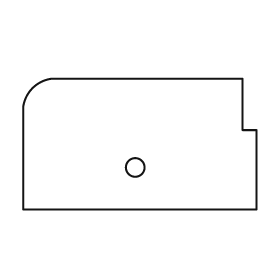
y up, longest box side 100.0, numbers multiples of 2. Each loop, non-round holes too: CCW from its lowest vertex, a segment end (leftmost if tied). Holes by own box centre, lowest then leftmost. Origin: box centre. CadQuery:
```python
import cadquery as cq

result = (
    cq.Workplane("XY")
    .moveTo(-50.0, -28.0)
    .lineTo(50.0, -28.0)
    .lineTo(50.0, 6.0)
    .lineTo(44.0, 6.0)
    .lineTo(44.0, 28.0)
    .lineTo(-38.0, 28.0)
    .threePointArc((-46.0, 24.0), (-50.0, 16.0))
    .close()
    .moveTo(-2.0, -10.0)
    .circle(4.0)
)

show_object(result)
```